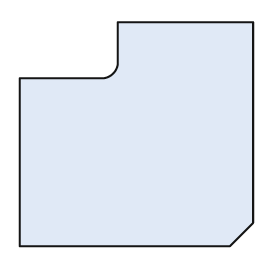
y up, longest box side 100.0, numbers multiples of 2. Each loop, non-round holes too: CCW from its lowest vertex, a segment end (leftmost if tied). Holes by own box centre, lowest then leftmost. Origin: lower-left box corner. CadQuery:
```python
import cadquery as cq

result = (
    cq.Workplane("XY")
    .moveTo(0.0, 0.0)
    .lineTo(90.0, 0.0)
    .lineTo(100.0, 10.0)
    .lineTo(100.0, 96.0)
    .lineTo(42.0, 96.0)
    .lineTo(42.0, 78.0)
    .threePointArc((40.0, 74.0), (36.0, 72.0))
    .lineTo(0.0, 72.0)
    .close()
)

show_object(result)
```